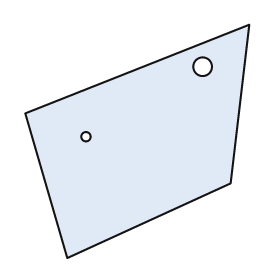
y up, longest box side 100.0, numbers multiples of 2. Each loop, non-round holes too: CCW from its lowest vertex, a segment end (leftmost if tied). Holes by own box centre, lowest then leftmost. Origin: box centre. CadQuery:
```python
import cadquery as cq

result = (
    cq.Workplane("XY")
    .moveTo(-30.0, -50.0)
    .lineTo(40.0, -18.0)
    .lineTo(48.0, 50.0)
    .lineTo(-48.0, 12.0)
    .close()
    .moveTo(-22.0, 2.0)
    .circle(2.0)
    .moveTo(28.0, 32.0)
    .circle(4.0)
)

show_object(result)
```